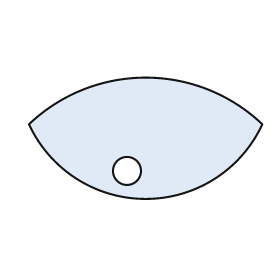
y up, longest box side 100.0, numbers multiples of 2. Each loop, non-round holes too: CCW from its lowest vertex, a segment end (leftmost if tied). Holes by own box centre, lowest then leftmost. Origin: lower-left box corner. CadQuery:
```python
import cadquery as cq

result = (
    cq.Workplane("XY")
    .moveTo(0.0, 32.0)
    .threePointArc((50.0, 0.0), (100.0, 32.0))
    .threePointArc((50.0, 52.0), (0.0, 32.0))
    .close()
    .moveTo(42.0, 12.0)
    .circle(6.0)
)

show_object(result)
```